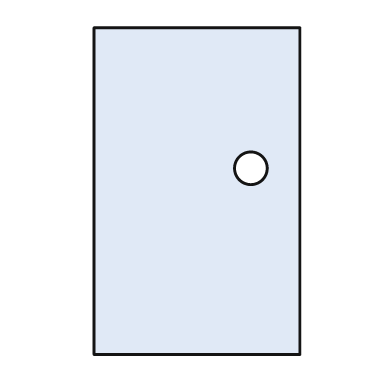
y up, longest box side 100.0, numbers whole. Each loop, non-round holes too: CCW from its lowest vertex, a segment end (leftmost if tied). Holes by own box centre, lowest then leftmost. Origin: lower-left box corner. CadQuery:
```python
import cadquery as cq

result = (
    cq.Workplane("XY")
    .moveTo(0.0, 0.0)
    .lineTo(63.0, 0.0)
    .lineTo(63.0, 100.0)
    .lineTo(0.0, 100.0)
    .close()
    .moveTo(48.0, 57.0)
    .circle(5.0)
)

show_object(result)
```